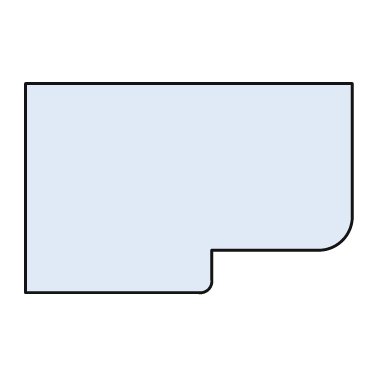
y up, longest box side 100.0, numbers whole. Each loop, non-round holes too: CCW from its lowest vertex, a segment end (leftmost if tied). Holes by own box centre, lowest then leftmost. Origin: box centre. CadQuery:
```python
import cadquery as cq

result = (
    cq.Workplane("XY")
    .moveTo(-50.0, -32.0)
    .lineTo(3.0, -32.0)
    .threePointArc((6.0, -31.0), (7.0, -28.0))
    .lineTo(7.0, -19.0)
    .lineTo(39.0, -19.0)
    .threePointArc((47.0, -16.0), (50.0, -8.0))
    .lineTo(50.0, 32.0)
    .lineTo(-50.0, 32.0)
    .close()
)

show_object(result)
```